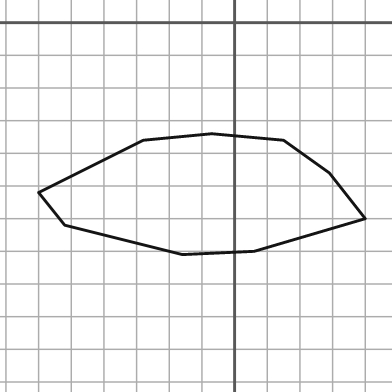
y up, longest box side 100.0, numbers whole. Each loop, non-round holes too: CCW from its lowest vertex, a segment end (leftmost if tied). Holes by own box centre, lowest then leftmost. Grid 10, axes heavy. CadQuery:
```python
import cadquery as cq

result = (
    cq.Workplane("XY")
    .moveTo(-16.0, -71.0)
    .lineTo(6.0, -70.0)
    .lineTo(40.0, -60.0)
    .lineTo(29.0, -46.0)
    .lineTo(15.0, -36.0)
    .lineTo(-7.0, -34.0)
    .lineTo(-28.0, -36.0)
    .lineTo(-60.0, -52.0)
    .lineTo(-52.0, -62.0)
    .close()
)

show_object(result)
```